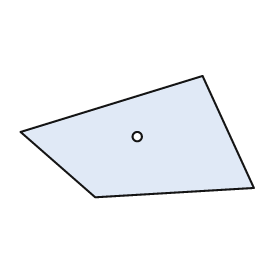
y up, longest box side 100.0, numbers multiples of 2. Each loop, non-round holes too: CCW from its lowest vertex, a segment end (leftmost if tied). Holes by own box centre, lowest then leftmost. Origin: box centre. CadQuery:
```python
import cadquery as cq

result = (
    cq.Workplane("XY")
    .moveTo(-18.0, -26.0)
    .lineTo(50.0, -22.0)
    .lineTo(28.0, 26.0)
    .lineTo(-50.0, 2.0)
    .close()
    .moveTo(0.0, 0.0)
    .circle(2.0)
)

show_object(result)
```